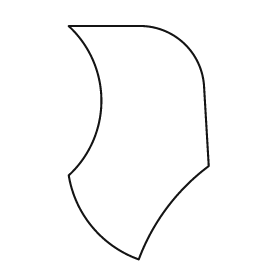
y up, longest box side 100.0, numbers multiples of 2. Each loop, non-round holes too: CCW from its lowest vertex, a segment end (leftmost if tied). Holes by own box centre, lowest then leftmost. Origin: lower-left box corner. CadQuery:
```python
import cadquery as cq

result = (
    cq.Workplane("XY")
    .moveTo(30.0, 0.0)
    .threePointArc((42.0, 22.0), (60.0, 40.0))
    .lineTo(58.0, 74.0)
    .threePointArc((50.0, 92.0), (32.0, 100.0))
    .lineTo(0.0, 100.0)
    .threePointArc((14.0, 68.0), (0.0, 36.0))
    .threePointArc((10.0, 14.0), (30.0, 0.0))
    .close()
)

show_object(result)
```